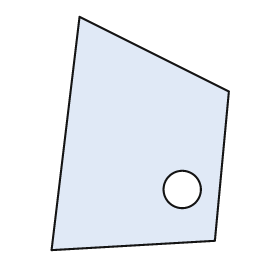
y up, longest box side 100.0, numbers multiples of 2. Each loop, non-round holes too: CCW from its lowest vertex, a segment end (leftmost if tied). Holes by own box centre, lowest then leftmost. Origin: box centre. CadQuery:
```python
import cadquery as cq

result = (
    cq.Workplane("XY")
    .moveTo(-38.0, -50.0)
    .lineTo(32.0, -46.0)
    .lineTo(38.0, 18.0)
    .lineTo(-26.0, 50.0)
    .close()
    .moveTo(18.0, -24.0)
    .circle(8.0)
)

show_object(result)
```